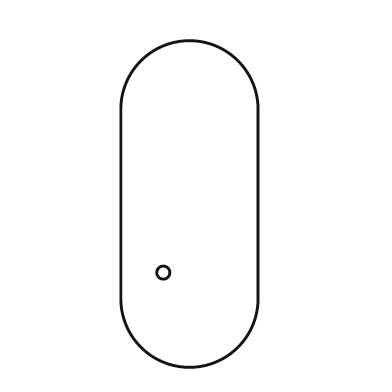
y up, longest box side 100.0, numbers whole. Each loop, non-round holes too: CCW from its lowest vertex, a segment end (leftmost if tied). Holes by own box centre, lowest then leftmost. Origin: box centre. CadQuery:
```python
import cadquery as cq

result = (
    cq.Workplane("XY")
    .moveTo(-21.0, -29.0)
    .threePointArc((0.0, -50.0), (21.0, -29.0))
    .lineTo(21.0, 29.0)
    .threePointArc((0.0, 50.0), (-21.0, 29.0))
    .close()
    .moveTo(-8.0, -21.0)
    .circle(2.0)
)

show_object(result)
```